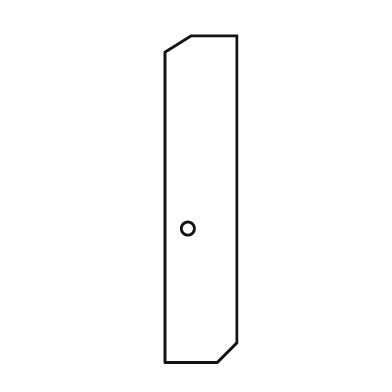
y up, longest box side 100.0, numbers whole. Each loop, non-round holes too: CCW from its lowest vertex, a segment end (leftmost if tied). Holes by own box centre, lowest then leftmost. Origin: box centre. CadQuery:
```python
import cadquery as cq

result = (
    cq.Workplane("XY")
    .moveTo(-11.0, -50.0)
    .lineTo(5.0, -50.0)
    .lineTo(11.0, -44.0)
    .lineTo(11.0, 50.0)
    .lineTo(-3.0, 50.0)
    .lineTo(-11.0, 45.0)
    .close()
    .moveTo(-4.0, -9.0)
    .circle(2.0)
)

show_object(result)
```